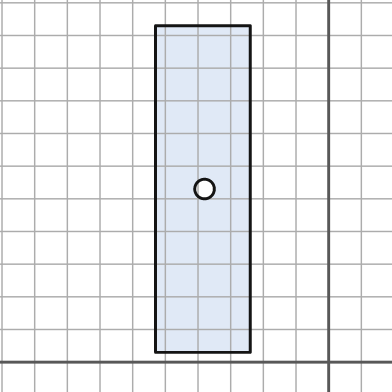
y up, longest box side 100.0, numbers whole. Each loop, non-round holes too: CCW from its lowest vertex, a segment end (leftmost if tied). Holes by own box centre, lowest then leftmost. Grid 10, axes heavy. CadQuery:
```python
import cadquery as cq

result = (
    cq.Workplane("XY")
    .moveTo(-53.0, 3.0)
    .lineTo(-24.0, 3.0)
    .lineTo(-24.0, 103.0)
    .lineTo(-53.0, 103.0)
    .close()
    .moveTo(-38.0, 53.0)
    .circle(3.0)
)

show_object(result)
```